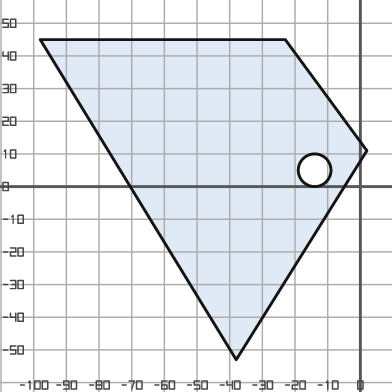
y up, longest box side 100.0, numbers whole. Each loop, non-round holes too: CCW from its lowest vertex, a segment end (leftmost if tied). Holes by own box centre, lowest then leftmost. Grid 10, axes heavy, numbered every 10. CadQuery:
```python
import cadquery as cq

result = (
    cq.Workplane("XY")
    .moveTo(-38.0, -53.0)
    .lineTo(2.0, 11.0)
    .lineTo(-23.0, 45.0)
    .lineTo(-98.0, 45.0)
    .close()
    .moveTo(-14.0, 5.0)
    .circle(5.0)
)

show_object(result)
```